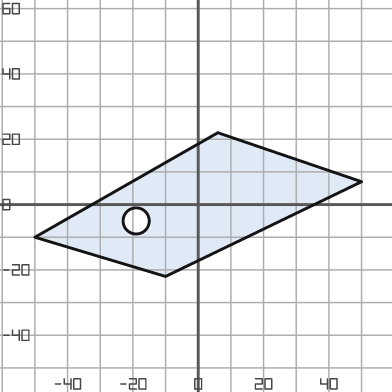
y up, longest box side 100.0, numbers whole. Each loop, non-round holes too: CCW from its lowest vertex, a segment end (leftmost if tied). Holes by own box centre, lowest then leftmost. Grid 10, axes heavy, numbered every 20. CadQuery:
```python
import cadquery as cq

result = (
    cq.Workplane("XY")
    .moveTo(-10.0, -22.0)
    .lineTo(50.0, 7.0)
    .lineTo(6.0, 22.0)
    .lineTo(-50.0, -10.0)
    .close()
    .moveTo(-19.0, -5.0)
    .circle(4.0)
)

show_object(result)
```